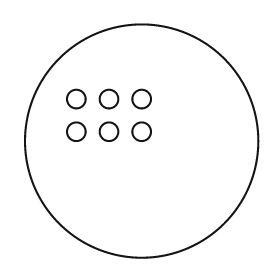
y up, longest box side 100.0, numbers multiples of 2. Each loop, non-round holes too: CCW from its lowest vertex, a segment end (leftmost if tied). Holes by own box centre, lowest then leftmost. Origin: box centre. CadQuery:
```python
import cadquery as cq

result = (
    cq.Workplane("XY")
    .moveTo(0.0, 0.0)
    .circle(50.0)
    .moveTo(-28.0, 4.0)
    .circle(4.0)
    .moveTo(-14.0, 4.0)
    .circle(4.0)
    .moveTo(0.0, 4.0)
    .circle(4.0)
    .moveTo(-28.0, 18.0)
    .circle(4.0)
    .moveTo(-14.0, 18.0)
    .circle(4.0)
    .moveTo(0.0, 18.0)
    .circle(4.0)
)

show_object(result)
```